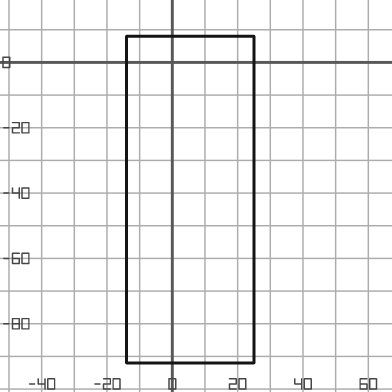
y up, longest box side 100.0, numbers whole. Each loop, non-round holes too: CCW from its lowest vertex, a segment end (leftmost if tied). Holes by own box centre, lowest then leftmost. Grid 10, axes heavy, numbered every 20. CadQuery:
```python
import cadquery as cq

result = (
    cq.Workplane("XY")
    .moveTo(-14.0, -92.0)
    .lineTo(25.0, -92.0)
    .lineTo(25.0, 8.0)
    .lineTo(-14.0, 8.0)
    .close()
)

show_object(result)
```